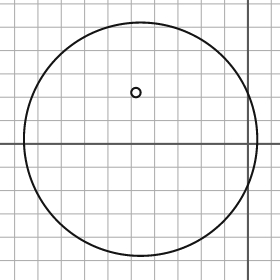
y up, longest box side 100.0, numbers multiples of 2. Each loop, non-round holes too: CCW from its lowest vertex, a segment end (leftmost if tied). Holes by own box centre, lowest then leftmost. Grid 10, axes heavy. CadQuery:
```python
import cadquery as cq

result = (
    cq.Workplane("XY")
    .moveTo(-46.0, 2.0)
    .circle(50.0)
    .moveTo(-48.0, 22.0)
    .circle(2.0)
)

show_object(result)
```